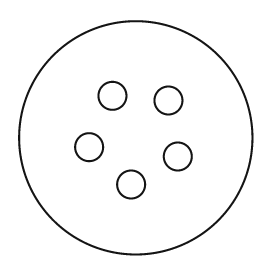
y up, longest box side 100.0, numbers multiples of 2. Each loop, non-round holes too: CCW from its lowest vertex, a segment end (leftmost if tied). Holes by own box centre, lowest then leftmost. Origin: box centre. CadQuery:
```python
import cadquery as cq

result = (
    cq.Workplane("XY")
    .moveTo(0.0, 0.0)
    .circle(50.0)
    .moveTo(-2.0, -20.0)
    .circle(6.0)
    .moveTo(18.0, -8.0)
    .circle(6.0)
    .moveTo(-20.0, -4.0)
    .circle(6.0)
    .moveTo(14.0, 16.0)
    .circle(6.0)
    .moveTo(-10.0, 18.0)
    .circle(6.0)
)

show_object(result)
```